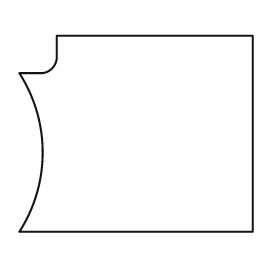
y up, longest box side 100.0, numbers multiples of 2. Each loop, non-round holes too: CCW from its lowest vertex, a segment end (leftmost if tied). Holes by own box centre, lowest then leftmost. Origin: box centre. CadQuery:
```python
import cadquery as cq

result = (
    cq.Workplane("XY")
    .moveTo(-50.0, -42.0)
    .lineTo(50.0, -42.0)
    .lineTo(50.0, 42.0)
    .lineTo(-34.0, 42.0)
    .lineTo(-34.0, 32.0)
    .threePointArc((-36.0, 28.0), (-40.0, 26.0))
    .lineTo(-50.0, 26.0)
    .threePointArc((-40.0, -8.0), (-50.0, -42.0))
    .close()
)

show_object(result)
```